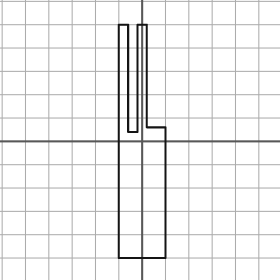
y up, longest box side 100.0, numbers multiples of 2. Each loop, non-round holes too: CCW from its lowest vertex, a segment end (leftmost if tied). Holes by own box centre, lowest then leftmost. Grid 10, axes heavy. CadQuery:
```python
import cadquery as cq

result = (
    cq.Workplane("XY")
    .moveTo(-10.0, -50.0)
    .lineTo(10.0, -50.0)
    .lineTo(10.0, 6.0)
    .lineTo(2.0, 6.0)
    .lineTo(2.0, 50.0)
    .lineTo(-2.0, 50.0)
    .lineTo(-2.0, 4.0)
    .lineTo(-6.0, 4.0)
    .lineTo(-6.0, 50.0)
    .lineTo(-10.0, 50.0)
    .close()
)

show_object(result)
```